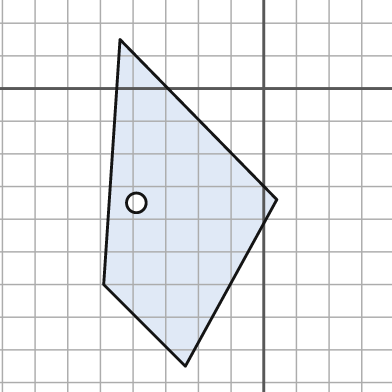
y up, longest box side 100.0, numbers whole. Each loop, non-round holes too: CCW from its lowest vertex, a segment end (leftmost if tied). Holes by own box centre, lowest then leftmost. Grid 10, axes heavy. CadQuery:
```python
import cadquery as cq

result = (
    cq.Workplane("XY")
    .moveTo(-24.0, -85.0)
    .lineTo(4.0, -34.0)
    .lineTo(-44.0, 15.0)
    .lineTo(-49.0, -60.0)
    .close()
    .moveTo(-39.0, -35.0)
    .circle(3.0)
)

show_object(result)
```